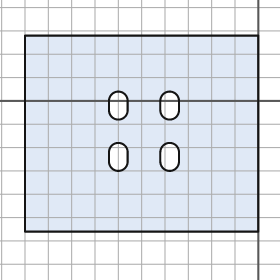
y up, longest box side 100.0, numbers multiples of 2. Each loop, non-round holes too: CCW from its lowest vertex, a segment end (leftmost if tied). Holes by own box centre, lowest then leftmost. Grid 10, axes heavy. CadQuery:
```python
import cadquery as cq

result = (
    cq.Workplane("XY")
    .moveTo(-100.0, -56.0)
    .lineTo(0.0, -56.0)
    .lineTo(0.0, 28.0)
    .lineTo(-100.0, 28.0)
    .close()
    .moveTo(-64.0, -26.0)
    .threePointArc((-60.0, -30.0), (-56.0, -26.0))
    .lineTo(-56.0, -22.0)
    .threePointArc((-60.0, -18.0), (-64.0, -22.0))
    .close()
    .moveTo(-42.0, -26.0)
    .threePointArc((-38.0, -30.0), (-34.0, -26.0))
    .lineTo(-34.0, -22.0)
    .threePointArc((-38.0, -18.0), (-42.0, -22.0))
    .close()
    .moveTo(-64.0, -4.0)
    .threePointArc((-60.0, -8.0), (-56.0, -4.0))
    .lineTo(-56.0, 0.0)
    .threePointArc((-60.0, 4.0), (-64.0, 0.0))
    .close()
    .moveTo(-42.0, -4.0)
    .threePointArc((-38.0, -8.0), (-34.0, -4.0))
    .lineTo(-34.0, 0.0)
    .threePointArc((-38.0, 4.0), (-42.0, 0.0))
    .close()
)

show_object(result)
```